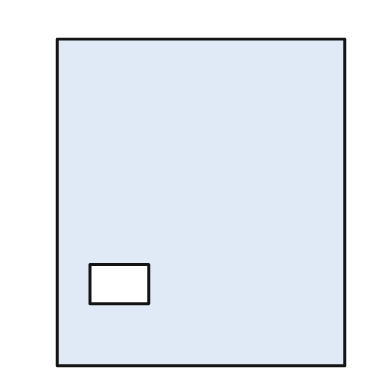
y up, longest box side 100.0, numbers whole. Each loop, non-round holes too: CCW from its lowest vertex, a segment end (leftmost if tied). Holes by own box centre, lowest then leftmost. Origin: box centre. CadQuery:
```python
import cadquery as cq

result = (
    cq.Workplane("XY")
    .moveTo(-44.0, -50.0)
    .lineTo(44.0, -50.0)
    .lineTo(44.0, 50.0)
    .lineTo(-44.0, 50.0)
    .close()
    .moveTo(-34.0, -31.0)
    .lineTo(-16.0, -31.0)
    .lineTo(-16.0, -19.0)
    .lineTo(-34.0, -19.0)
    .close()
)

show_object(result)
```